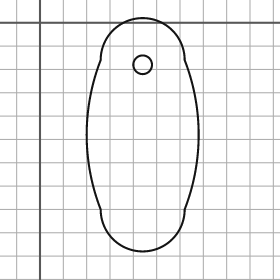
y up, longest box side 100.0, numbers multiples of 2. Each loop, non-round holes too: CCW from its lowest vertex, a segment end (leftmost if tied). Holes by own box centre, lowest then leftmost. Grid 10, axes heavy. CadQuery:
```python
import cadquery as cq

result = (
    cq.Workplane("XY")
    .moveTo(26.0, -80.0)
    .threePointArc((44.0, -98.0), (62.0, -80.0))
    .threePointArc((68.0, -48.0), (62.0, -16.0))
    .threePointArc((44.0, 2.0), (26.0, -16.0))
    .threePointArc((20.0, -48.0), (26.0, -80.0))
    .close()
    .moveTo(44.0, -18.0)
    .circle(4.0)
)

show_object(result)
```